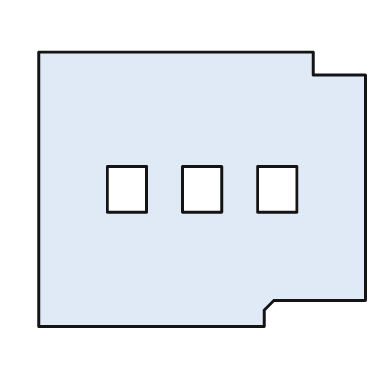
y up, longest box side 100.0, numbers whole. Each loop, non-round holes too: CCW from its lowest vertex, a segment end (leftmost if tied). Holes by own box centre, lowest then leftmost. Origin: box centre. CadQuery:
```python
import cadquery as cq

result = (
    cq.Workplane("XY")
    .moveTo(-50.0, -42.0)
    .lineTo(19.0, -42.0)
    .lineTo(19.0, -37.0)
    .lineTo(22.0, -34.0)
    .lineTo(50.0, -34.0)
    .lineTo(50.0, 35.0)
    .lineTo(34.0, 35.0)
    .lineTo(34.0, 42.0)
    .lineTo(-50.0, 42.0)
    .close()
    .moveTo(-29.0, -7.0)
    .lineTo(-17.0, -7.0)
    .lineTo(-17.0, 7.0)
    .lineTo(-29.0, 7.0)
    .close()
    .moveTo(-6.0, -7.0)
    .lineTo(6.0, -7.0)
    .lineTo(6.0, 7.0)
    .lineTo(-6.0, 7.0)
    .close()
    .moveTo(17.0, -7.0)
    .lineTo(29.0, -7.0)
    .lineTo(29.0, 7.0)
    .lineTo(17.0, 7.0)
    .close()
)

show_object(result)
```